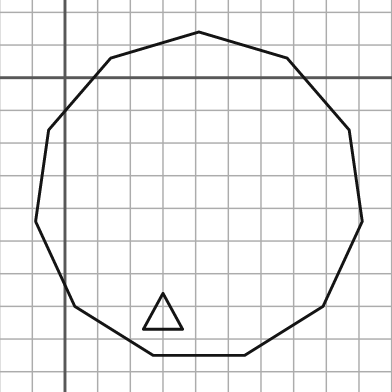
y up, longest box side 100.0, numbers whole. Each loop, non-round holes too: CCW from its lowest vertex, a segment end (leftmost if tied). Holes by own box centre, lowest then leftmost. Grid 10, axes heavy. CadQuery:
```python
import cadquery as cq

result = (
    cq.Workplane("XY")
    .moveTo(27.0, -85.0)
    .lineTo(55.0, -85.0)
    .lineTo(79.0, -70.0)
    .lineTo(91.0, -44.0)
    .lineTo(87.0, -16.0)
    .lineTo(68.0, 6.0)
    .lineTo(41.0, 14.0)
    .lineTo(14.0, 6.0)
    .lineTo(-5.0, -16.0)
    .lineTo(-9.0, -44.0)
    .lineTo(3.0, -70.0)
    .close()
    .moveTo(24.0, -77.0)
    .lineTo(36.0, -77.0)
    .lineTo(30.0, -66.0)
    .close()
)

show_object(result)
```